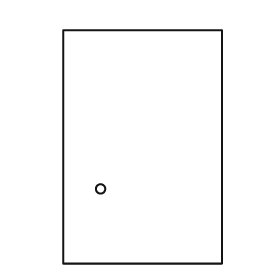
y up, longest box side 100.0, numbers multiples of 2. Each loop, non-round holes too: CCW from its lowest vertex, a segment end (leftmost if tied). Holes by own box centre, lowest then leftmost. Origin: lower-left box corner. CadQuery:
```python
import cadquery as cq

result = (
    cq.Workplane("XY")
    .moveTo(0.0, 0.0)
    .lineTo(68.0, 0.0)
    .lineTo(68.0, 100.0)
    .lineTo(0.0, 100.0)
    .close()
    .moveTo(16.0, 32.0)
    .circle(2.0)
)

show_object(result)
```